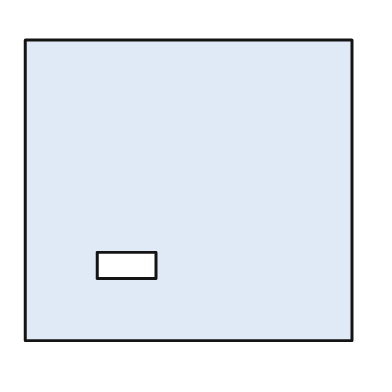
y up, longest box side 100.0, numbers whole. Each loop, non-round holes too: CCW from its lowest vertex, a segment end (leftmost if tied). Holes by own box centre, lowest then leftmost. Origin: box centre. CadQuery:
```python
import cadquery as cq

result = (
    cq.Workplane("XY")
    .moveTo(-50.0, -46.0)
    .lineTo(50.0, -46.0)
    .lineTo(50.0, 46.0)
    .lineTo(-50.0, 46.0)
    .close()
    .moveTo(-28.0, -27.0)
    .lineTo(-10.0, -27.0)
    .lineTo(-10.0, -19.0)
    .lineTo(-28.0, -19.0)
    .close()
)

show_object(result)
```